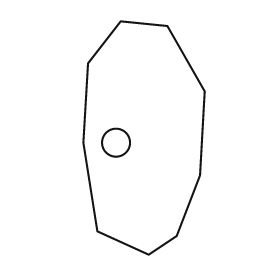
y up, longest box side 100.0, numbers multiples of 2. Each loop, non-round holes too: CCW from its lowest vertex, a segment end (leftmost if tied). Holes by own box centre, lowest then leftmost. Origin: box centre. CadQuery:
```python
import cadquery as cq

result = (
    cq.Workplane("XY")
    .moveTo(2.0, -50.0)
    .lineTo(14.0, -42.0)
    .lineTo(24.0, -16.0)
    .lineTo(26.0, 20.0)
    .lineTo(10.0, 48.0)
    .lineTo(-10.0, 50.0)
    .lineTo(-24.0, 32.0)
    .lineTo(-26.0, -2.0)
    .lineTo(-20.0, -40.0)
    .close()
    .moveTo(-12.0, -2.0)
    .circle(6.0)
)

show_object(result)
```